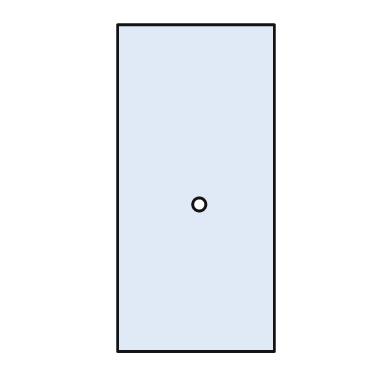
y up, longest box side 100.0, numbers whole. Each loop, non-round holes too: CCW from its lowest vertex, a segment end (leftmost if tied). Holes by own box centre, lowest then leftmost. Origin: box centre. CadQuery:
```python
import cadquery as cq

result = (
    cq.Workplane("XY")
    .moveTo(-24.0, -50.0)
    .lineTo(24.0, -50.0)
    .lineTo(24.0, 50.0)
    .lineTo(-24.0, 50.0)
    .close()
    .moveTo(1.0, -5.0)
    .circle(2.0)
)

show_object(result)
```